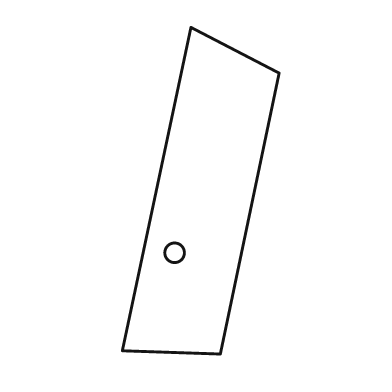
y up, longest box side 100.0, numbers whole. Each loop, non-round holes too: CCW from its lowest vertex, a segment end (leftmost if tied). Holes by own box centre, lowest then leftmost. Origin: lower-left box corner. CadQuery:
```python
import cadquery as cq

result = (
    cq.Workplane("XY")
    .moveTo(30.0, 0.0)
    .lineTo(48.0, 86.0)
    .lineTo(21.0, 100.0)
    .lineTo(0.0, 1.0)
    .close()
    .moveTo(16.0, 31.0)
    .circle(3.0)
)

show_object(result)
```